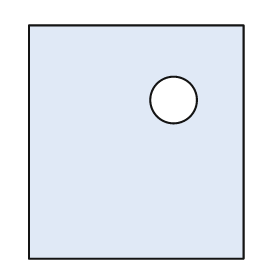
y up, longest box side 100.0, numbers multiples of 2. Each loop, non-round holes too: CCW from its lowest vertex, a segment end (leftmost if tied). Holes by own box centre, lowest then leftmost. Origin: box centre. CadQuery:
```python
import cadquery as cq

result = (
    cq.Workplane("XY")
    .moveTo(-46.0, -50.0)
    .lineTo(46.0, -50.0)
    .lineTo(46.0, 50.0)
    .lineTo(-46.0, 50.0)
    .close()
    .moveTo(16.0, 18.0)
    .circle(10.0)
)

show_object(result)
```